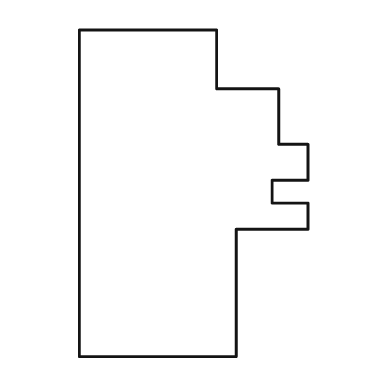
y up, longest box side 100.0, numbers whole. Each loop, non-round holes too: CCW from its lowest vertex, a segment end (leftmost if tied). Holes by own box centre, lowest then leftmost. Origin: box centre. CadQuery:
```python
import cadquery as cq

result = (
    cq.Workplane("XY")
    .moveTo(-35.0, -50.0)
    .lineTo(13.0, -50.0)
    .lineTo(13.0, -11.0)
    .lineTo(35.0, -11.0)
    .lineTo(35.0, -3.0)
    .lineTo(24.0, -3.0)
    .lineTo(24.0, 4.0)
    .lineTo(35.0, 4.0)
    .lineTo(35.0, 15.0)
    .lineTo(26.0, 15.0)
    .lineTo(26.0, 32.0)
    .lineTo(7.0, 32.0)
    .lineTo(7.0, 50.0)
    .lineTo(-35.0, 50.0)
    .close()
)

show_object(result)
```